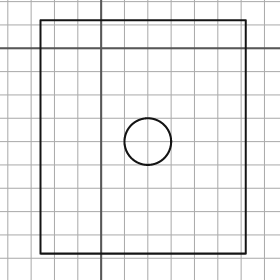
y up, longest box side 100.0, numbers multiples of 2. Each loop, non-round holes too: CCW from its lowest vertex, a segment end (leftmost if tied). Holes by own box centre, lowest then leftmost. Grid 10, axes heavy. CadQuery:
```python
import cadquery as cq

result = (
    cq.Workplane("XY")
    .moveTo(-26.0, -88.0)
    .lineTo(62.0, -88.0)
    .lineTo(62.0, 12.0)
    .lineTo(-26.0, 12.0)
    .close()
    .moveTo(20.0, -40.0)
    .circle(10.0)
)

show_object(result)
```